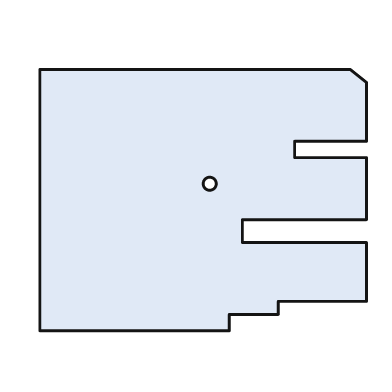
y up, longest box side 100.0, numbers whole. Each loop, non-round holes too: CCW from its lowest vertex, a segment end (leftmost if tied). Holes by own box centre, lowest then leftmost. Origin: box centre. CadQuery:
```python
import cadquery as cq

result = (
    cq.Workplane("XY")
    .moveTo(-50.0, -40.0)
    .lineTo(8.0, -40.0)
    .lineTo(8.0, -35.0)
    .lineTo(23.0, -35.0)
    .lineTo(23.0, -31.0)
    .lineTo(50.0, -31.0)
    .lineTo(50.0, -13.0)
    .lineTo(12.0, -13.0)
    .lineTo(12.0, -6.0)
    .lineTo(50.0, -6.0)
    .lineTo(50.0, 13.0)
    .lineTo(28.0, 13.0)
    .lineTo(28.0, 18.0)
    .lineTo(50.0, 18.0)
    .lineTo(50.0, 36.0)
    .lineTo(45.0, 40.0)
    .lineTo(-50.0, 40.0)
    .close()
    .moveTo(2.0, 5.0)
    .circle(2.0)
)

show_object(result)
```